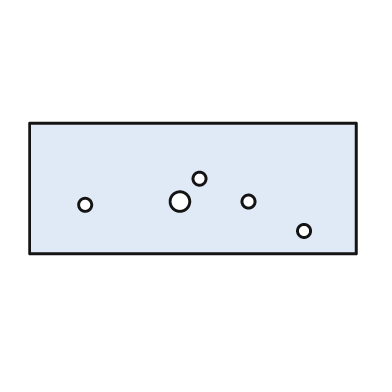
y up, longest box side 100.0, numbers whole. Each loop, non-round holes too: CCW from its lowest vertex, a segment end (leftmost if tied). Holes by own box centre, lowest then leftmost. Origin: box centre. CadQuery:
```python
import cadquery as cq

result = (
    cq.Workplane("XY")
    .moveTo(-50.0, -20.0)
    .lineTo(50.0, -20.0)
    .lineTo(50.0, 20.0)
    .lineTo(-50.0, 20.0)
    .close()
    .moveTo(34.0, -13.0)
    .circle(2.0)
    .moveTo(-33.0, -5.0)
    .circle(2.0)
    .moveTo(-4.0, -4.0)
    .circle(3.0)
    .moveTo(17.0, -4.0)
    .circle(2.0)
    .moveTo(2.0, 3.0)
    .circle(2.0)
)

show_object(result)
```